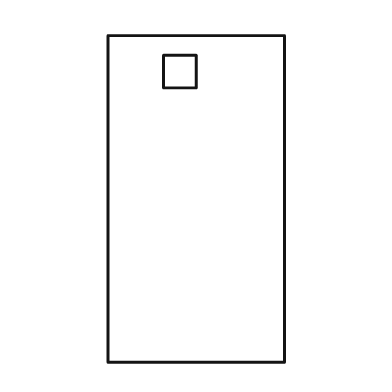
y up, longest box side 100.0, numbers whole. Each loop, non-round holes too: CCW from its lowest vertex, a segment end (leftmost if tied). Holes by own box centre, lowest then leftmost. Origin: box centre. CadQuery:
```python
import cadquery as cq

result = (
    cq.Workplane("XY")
    .moveTo(-27.0, -50.0)
    .lineTo(27.0, -50.0)
    .lineTo(27.0, 50.0)
    .lineTo(-27.0, 50.0)
    .close()
    .moveTo(-10.0, 34.0)
    .lineTo(0.0, 34.0)
    .lineTo(0.0, 44.0)
    .lineTo(-10.0, 44.0)
    .close()
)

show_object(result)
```